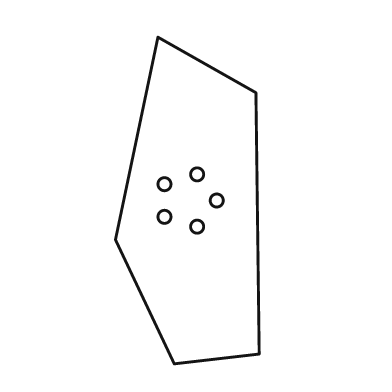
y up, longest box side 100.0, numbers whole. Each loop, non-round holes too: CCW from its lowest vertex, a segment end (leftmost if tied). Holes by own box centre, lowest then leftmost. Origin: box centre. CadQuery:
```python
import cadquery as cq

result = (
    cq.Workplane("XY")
    .moveTo(-4.0, -50.0)
    .lineTo(22.0, -47.0)
    .lineTo(21.0, 33.0)
    .lineTo(-9.0, 50.0)
    .lineTo(-22.0, -12.0)
    .close()
    .moveTo(3.0, -8.0)
    .circle(2.0)
    .moveTo(-7.0, -5.0)
    .circle(2.0)
    .moveTo(9.0, 0.0)
    .circle(2.0)
    .moveTo(-7.0, 5.0)
    .circle(2.0)
    .moveTo(3.0, 8.0)
    .circle(2.0)
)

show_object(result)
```